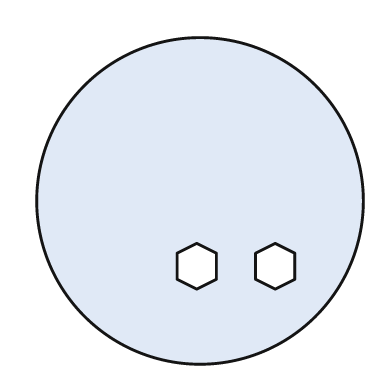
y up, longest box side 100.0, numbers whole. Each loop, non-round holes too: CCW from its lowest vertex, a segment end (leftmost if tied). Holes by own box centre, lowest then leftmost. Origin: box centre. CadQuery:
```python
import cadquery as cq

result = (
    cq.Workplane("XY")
    .moveTo(0.0, 0.0)
    .circle(50.0)
    .moveTo(-1.0, -27.0)
    .lineTo(5.0, -24.0)
    .lineTo(5.0, -16.0)
    .lineTo(-1.0, -13.0)
    .lineTo(-7.0, -16.0)
    .lineTo(-7.0, -24.0)
    .close()
    .moveTo(23.0, -27.0)
    .lineTo(29.0, -24.0)
    .lineTo(29.0, -16.0)
    .lineTo(23.0, -13.0)
    .lineTo(17.0, -16.0)
    .lineTo(17.0, -24.0)
    .close()
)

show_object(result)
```